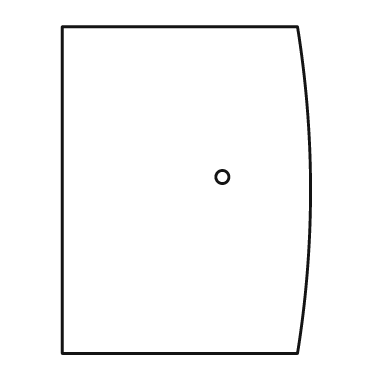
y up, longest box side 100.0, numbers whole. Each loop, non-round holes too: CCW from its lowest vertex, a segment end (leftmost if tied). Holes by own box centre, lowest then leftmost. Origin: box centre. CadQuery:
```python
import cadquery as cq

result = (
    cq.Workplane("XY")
    .moveTo(-38.0, -50.0)
    .lineTo(34.0, -50.0)
    .threePointArc((38.0, 0.0), (34.0, 50.0))
    .lineTo(-38.0, 50.0)
    .close()
    .moveTo(11.0, 4.0)
    .circle(2.0)
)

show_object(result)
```